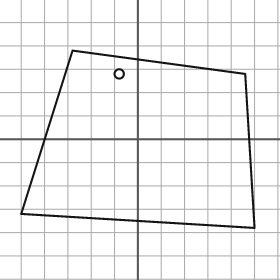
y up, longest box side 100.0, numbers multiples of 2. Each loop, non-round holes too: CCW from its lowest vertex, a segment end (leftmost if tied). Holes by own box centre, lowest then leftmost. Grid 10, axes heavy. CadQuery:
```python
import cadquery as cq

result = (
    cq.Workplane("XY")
    .moveTo(50.0, -38.0)
    .lineTo(46.0, 28.0)
    .lineTo(-28.0, 38.0)
    .lineTo(-50.0, -32.0)
    .close()
    .moveTo(-8.0, 28.0)
    .circle(2.0)
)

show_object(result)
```